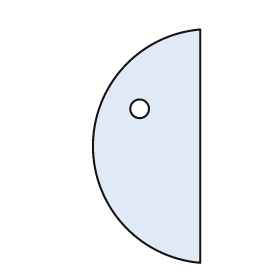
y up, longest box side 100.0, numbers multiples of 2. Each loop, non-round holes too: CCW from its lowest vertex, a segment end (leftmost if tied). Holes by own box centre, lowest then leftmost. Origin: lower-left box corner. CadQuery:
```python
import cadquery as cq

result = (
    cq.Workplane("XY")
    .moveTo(46.0, 0.0)
    .lineTo(46.0, 100.0)
    .threePointArc((0.0, 50.0), (46.0, 0.0))
    .close()
    .moveTo(20.0, 66.0)
    .circle(4.0)
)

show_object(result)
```